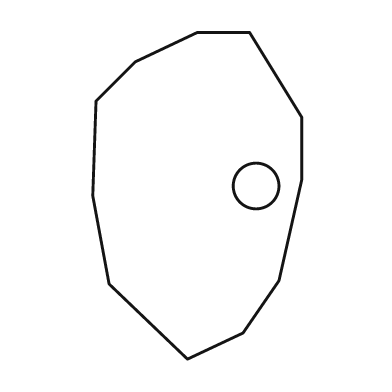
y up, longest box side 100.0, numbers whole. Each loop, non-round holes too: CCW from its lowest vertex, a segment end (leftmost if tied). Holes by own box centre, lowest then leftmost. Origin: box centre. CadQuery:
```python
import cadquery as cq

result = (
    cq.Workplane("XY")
    .moveTo(-3.0, -50.0)
    .lineTo(14.0, -42.0)
    .lineTo(25.0, -26.0)
    .lineTo(32.0, 5.0)
    .lineTo(32.0, 24.0)
    .lineTo(16.0, 50.0)
    .lineTo(0.0, 50.0)
    .lineTo(-19.0, 41.0)
    .lineTo(-31.0, 29.0)
    .lineTo(-32.0, 0.0)
    .lineTo(-27.0, -27.0)
    .close()
    .moveTo(18.0, 3.0)
    .circle(7.0)
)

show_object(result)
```